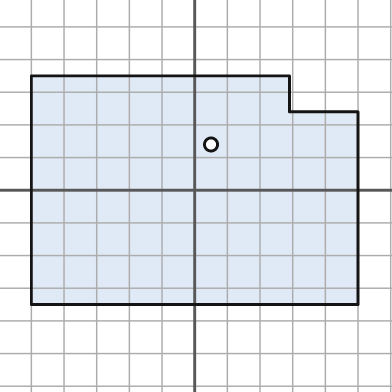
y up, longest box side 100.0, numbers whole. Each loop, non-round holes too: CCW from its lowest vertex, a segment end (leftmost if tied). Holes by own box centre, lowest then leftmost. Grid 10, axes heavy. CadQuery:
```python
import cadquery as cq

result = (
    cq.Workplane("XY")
    .moveTo(-50.0, -35.0)
    .lineTo(50.0, -35.0)
    .lineTo(50.0, 24.0)
    .lineTo(29.0, 24.0)
    .lineTo(29.0, 35.0)
    .lineTo(-50.0, 35.0)
    .close()
    .moveTo(5.0, 14.0)
    .circle(2.0)
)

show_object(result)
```